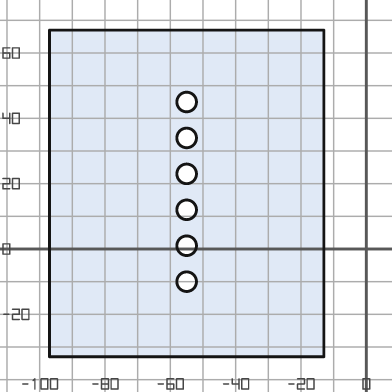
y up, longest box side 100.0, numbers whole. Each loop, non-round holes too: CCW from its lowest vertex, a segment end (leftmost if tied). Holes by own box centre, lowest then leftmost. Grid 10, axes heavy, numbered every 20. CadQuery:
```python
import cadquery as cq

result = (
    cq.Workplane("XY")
    .moveTo(-97.0, -33.0)
    .lineTo(-13.0, -33.0)
    .lineTo(-13.0, 67.0)
    .lineTo(-97.0, 67.0)
    .close()
    .moveTo(-55.0, -10.0)
    .circle(3.0)
    .moveTo(-55.0, 1.0)
    .circle(3.0)
    .moveTo(-55.0, 12.0)
    .circle(3.0)
    .moveTo(-55.0, 23.0)
    .circle(3.0)
    .moveTo(-55.0, 34.0)
    .circle(3.0)
    .moveTo(-55.0, 45.0)
    .circle(3.0)
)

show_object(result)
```